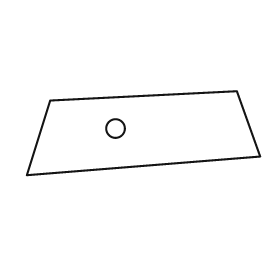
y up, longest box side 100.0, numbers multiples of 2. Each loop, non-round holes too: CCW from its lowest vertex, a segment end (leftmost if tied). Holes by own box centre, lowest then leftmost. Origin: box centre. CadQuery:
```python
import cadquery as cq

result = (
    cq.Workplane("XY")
    .moveTo(-50.0, -18.0)
    .lineTo(50.0, -10.0)
    .lineTo(40.0, 18.0)
    .lineTo(-40.0, 14.0)
    .close()
    .moveTo(-12.0, 2.0)
    .circle(4.0)
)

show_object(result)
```